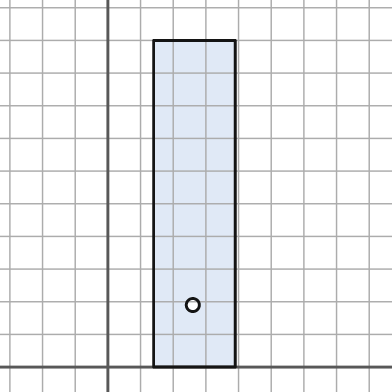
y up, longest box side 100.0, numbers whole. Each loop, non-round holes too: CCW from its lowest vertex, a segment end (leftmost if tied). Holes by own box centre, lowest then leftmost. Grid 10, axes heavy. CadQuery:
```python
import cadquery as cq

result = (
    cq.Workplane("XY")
    .moveTo(14.0, 0.0)
    .lineTo(39.0, 0.0)
    .lineTo(39.0, 100.0)
    .lineTo(14.0, 100.0)
    .close()
    .moveTo(26.0, 19.0)
    .circle(2.0)
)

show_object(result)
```